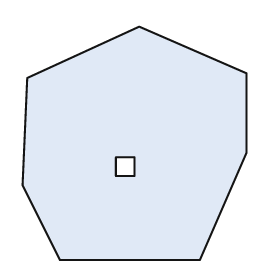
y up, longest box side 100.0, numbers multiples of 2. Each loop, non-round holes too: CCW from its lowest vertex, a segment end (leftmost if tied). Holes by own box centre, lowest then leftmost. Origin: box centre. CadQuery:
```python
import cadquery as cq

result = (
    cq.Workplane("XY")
    .moveTo(-32.0, -50.0)
    .lineTo(28.0, -50.0)
    .lineTo(48.0, -4.0)
    .lineTo(48.0, 30.0)
    .lineTo(2.0, 50.0)
    .lineTo(-46.0, 28.0)
    .lineTo(-48.0, -18.0)
    .close()
    .moveTo(-8.0, -14.0)
    .lineTo(0.0, -14.0)
    .lineTo(0.0, -6.0)
    .lineTo(-8.0, -6.0)
    .close()
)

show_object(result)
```